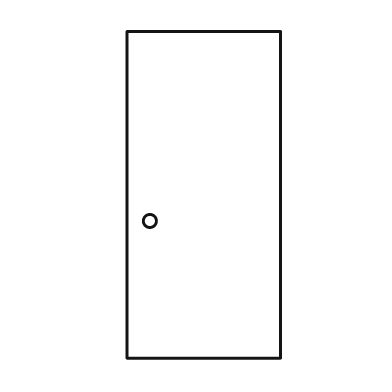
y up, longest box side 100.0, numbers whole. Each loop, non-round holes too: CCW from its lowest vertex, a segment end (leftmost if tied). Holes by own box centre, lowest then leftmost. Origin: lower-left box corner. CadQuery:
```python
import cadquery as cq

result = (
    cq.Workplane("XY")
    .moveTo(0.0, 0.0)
    .lineTo(47.0, 0.0)
    .lineTo(47.0, 100.0)
    .lineTo(0.0, 100.0)
    .close()
    .moveTo(7.0, 42.0)
    .circle(2.0)
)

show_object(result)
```